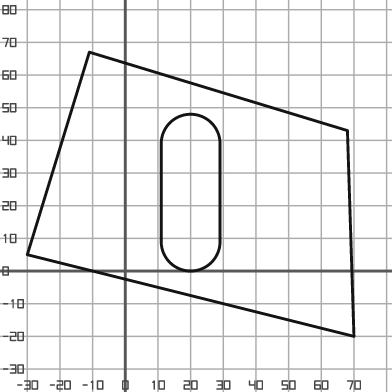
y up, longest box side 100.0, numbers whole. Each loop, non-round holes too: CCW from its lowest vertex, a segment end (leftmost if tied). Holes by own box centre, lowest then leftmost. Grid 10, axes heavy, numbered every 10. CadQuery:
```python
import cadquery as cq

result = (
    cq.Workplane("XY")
    .moveTo(70.0, -20.0)
    .lineTo(68.0, 43.0)
    .lineTo(-11.0, 67.0)
    .lineTo(-30.0, 5.0)
    .close()
    .moveTo(11.0, 9.0)
    .threePointArc((20.0, 0.0), (29.0, 9.0))
    .lineTo(29.0, 39.0)
    .threePointArc((20.0, 48.0), (11.0, 39.0))
    .close()
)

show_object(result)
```